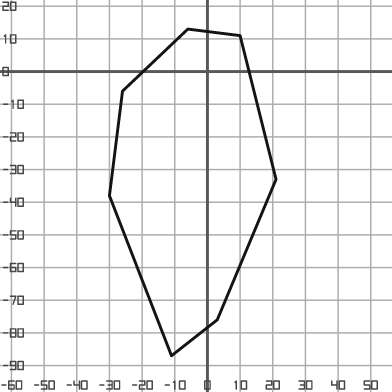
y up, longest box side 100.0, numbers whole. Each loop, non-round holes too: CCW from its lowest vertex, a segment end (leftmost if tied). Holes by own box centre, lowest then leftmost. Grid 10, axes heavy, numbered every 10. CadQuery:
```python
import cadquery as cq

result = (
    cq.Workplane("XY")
    .moveTo(-11.0, -87.0)
    .lineTo(3.0, -76.0)
    .lineTo(21.0, -33.0)
    .lineTo(10.0, 11.0)
    .lineTo(-6.0, 13.0)
    .lineTo(-26.0, -6.0)
    .lineTo(-30.0, -38.0)
    .close()
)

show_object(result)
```